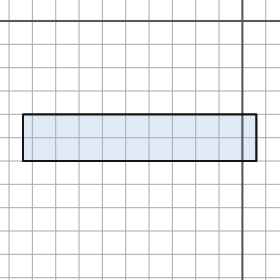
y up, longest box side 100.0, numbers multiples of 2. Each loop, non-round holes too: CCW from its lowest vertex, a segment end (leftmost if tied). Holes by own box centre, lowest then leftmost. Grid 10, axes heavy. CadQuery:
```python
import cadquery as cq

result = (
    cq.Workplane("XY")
    .moveTo(-94.0, -60.0)
    .lineTo(6.0, -60.0)
    .lineTo(6.0, -40.0)
    .lineTo(-94.0, -40.0)
    .close()
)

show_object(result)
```